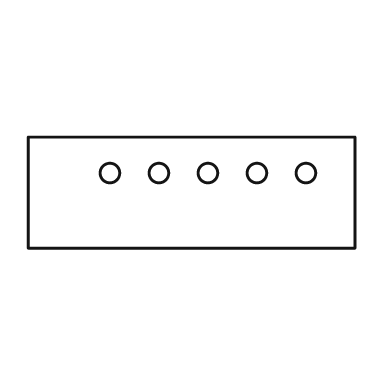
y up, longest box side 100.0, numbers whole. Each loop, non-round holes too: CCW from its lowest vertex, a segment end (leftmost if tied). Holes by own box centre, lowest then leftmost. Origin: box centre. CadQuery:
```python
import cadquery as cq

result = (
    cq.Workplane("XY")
    .moveTo(-50.0, -17.0)
    .lineTo(50.0, -17.0)
    .lineTo(50.0, 17.0)
    .lineTo(-50.0, 17.0)
    .close()
    .moveTo(-25.0, 6.0)
    .circle(3.0)
    .moveTo(-10.0, 6.0)
    .circle(3.0)
    .moveTo(5.0, 6.0)
    .circle(3.0)
    .moveTo(20.0, 6.0)
    .circle(3.0)
    .moveTo(35.0, 6.0)
    .circle(3.0)
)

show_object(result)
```